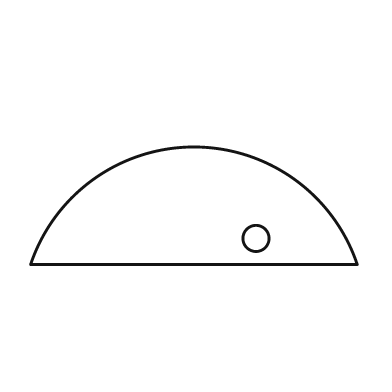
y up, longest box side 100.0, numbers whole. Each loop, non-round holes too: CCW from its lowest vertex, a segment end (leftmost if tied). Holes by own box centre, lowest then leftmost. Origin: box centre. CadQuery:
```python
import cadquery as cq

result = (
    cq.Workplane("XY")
    .moveTo(-50.0, -18.0)
    .lineTo(50.0, -18.0)
    .threePointArc((0.0, 18.0), (-50.0, -18.0))
    .close()
    .moveTo(19.0, -10.0)
    .circle(4.0)
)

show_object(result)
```